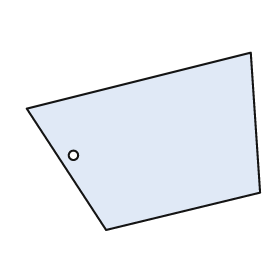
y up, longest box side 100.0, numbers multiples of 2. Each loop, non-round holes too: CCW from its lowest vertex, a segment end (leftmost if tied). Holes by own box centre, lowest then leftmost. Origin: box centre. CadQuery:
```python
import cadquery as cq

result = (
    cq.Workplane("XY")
    .moveTo(-16.0, -38.0)
    .lineTo(50.0, -22.0)
    .lineTo(46.0, 38.0)
    .lineTo(-50.0, 14.0)
    .close()
    .moveTo(-30.0, -6.0)
    .circle(2.0)
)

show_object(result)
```